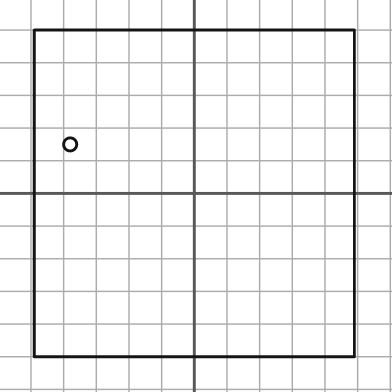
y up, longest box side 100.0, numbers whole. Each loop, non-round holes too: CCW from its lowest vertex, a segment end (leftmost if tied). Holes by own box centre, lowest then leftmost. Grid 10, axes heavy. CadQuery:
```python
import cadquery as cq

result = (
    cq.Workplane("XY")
    .moveTo(-49.0, -50.0)
    .lineTo(49.0, -50.0)
    .lineTo(49.0, 50.0)
    .lineTo(-49.0, 50.0)
    .close()
    .moveTo(-38.0, 15.0)
    .circle(2.0)
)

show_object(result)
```